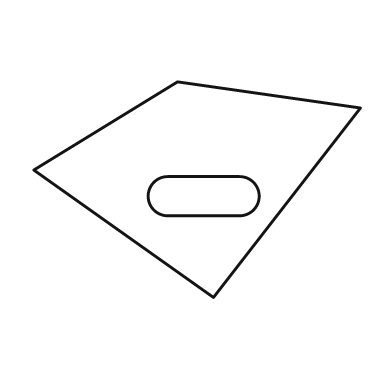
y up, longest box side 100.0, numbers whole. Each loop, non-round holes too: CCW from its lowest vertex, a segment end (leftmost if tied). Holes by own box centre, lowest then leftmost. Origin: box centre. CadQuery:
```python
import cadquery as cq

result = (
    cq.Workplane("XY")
    .moveTo(5.0, -33.0)
    .lineTo(50.0, 25.0)
    .lineTo(-6.0, 33.0)
    .lineTo(-50.0, 6.0)
    .close()
    .moveTo(-9.0, -8.0)
    .lineTo(13.0, -8.0)
    .threePointArc((19.0, -2.0), (13.0, 4.0))
    .lineTo(-9.0, 4.0)
    .threePointArc((-15.0, -2.0), (-9.0, -8.0))
    .close()
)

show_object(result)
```